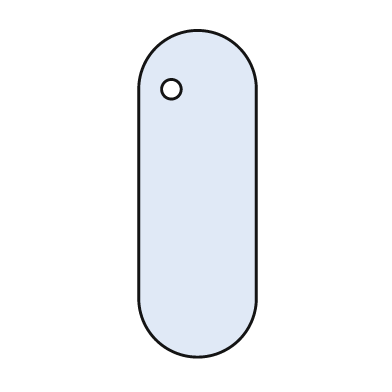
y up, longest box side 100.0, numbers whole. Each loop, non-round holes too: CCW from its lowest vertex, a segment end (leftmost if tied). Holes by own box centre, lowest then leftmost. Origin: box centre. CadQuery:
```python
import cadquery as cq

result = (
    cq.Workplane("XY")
    .moveTo(-18.0, -32.0)
    .threePointArc((0.0, -50.0), (18.0, -32.0))
    .lineTo(18.0, 32.0)
    .threePointArc((0.0, 50.0), (-18.0, 32.0))
    .close()
    .moveTo(-8.0, 32.0)
    .circle(3.0)
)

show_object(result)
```